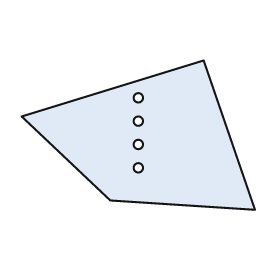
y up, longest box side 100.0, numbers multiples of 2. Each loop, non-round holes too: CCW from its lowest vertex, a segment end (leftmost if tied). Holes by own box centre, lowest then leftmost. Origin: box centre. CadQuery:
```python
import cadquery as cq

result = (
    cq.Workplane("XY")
    .moveTo(50.0, -32.0)
    .lineTo(28.0, 32.0)
    .lineTo(-50.0, 8.0)
    .lineTo(-12.0, -28.0)
    .close()
    .moveTo(0.0, -14.0)
    .circle(2.0)
    .moveTo(0.0, -4.0)
    .circle(2.0)
    .moveTo(0.0, 6.0)
    .circle(2.0)
    .moveTo(0.0, 16.0)
    .circle(2.0)
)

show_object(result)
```